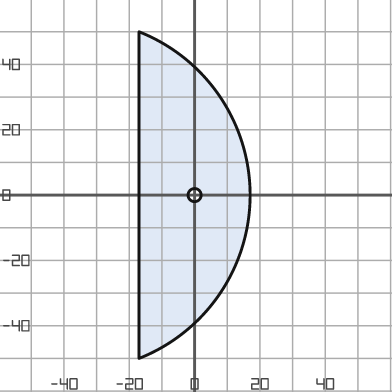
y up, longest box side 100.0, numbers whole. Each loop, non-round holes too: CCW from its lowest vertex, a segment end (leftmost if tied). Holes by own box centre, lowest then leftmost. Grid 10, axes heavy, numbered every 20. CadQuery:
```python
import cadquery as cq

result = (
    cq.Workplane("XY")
    .moveTo(-17.0, -50.0)
    .threePointArc((17.0, 0.0), (-17.0, 50.0))
    .close()
    .moveTo(0.0, 0.0)
    .circle(2.0)
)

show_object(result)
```